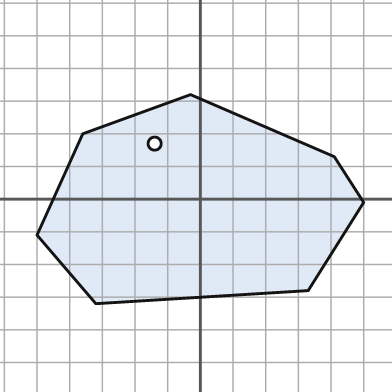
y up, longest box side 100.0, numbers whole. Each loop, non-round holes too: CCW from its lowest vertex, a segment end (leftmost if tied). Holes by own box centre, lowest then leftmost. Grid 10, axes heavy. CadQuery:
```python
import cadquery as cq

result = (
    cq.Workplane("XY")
    .moveTo(-32.0, -32.0)
    .lineTo(33.0, -28.0)
    .lineTo(50.0, -1.0)
    .lineTo(41.0, 13.0)
    .lineTo(-3.0, 32.0)
    .lineTo(-36.0, 20.0)
    .lineTo(-50.0, -11.0)
    .close()
    .moveTo(-14.0, 17.0)
    .circle(2.0)
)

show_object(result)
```